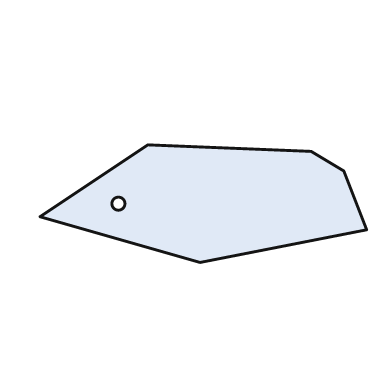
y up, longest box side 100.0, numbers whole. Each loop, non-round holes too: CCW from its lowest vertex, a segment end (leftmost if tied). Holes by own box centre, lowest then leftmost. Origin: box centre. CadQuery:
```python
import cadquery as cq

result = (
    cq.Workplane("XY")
    .moveTo(-1.0, -18.0)
    .lineTo(50.0, -8.0)
    .lineTo(43.0, 10.0)
    .lineTo(33.0, 16.0)
    .lineTo(-17.0, 18.0)
    .lineTo(-50.0, -4.0)
    .close()
    .moveTo(-26.0, 0.0)
    .circle(2.0)
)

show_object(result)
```